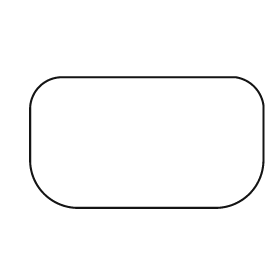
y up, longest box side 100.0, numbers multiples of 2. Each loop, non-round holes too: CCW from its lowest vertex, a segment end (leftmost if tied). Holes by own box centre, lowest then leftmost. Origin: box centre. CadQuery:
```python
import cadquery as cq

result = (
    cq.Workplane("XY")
    .moveTo(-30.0, -28.0)
    .lineTo(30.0, -28.0)
    .threePointArc((44.0, -22.0), (50.0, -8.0))
    .lineTo(50.0, 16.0)
    .threePointArc((46.0, 24.0), (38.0, 28.0))
    .lineTo(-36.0, 28.0)
    .threePointArc((-46.0, 24.0), (-50.0, 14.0))
    .lineTo(-50.0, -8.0)
    .threePointArc((-44.0, -22.0), (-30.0, -28.0))
    .close()
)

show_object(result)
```